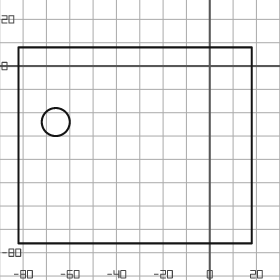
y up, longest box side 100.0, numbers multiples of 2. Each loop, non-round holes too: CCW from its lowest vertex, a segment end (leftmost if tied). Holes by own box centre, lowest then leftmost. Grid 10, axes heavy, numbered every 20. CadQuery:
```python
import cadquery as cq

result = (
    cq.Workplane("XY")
    .moveTo(-82.0, -76.0)
    .lineTo(18.0, -76.0)
    .lineTo(18.0, 8.0)
    .lineTo(-82.0, 8.0)
    .close()
    .moveTo(-66.0, -24.0)
    .circle(6.0)
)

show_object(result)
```